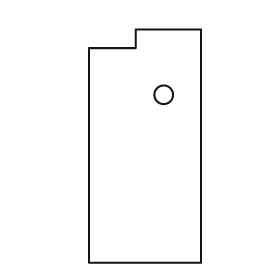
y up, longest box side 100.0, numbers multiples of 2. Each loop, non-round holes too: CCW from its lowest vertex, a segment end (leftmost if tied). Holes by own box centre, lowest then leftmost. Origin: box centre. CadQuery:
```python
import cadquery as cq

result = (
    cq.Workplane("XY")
    .moveTo(-24.0, -50.0)
    .lineTo(24.0, -50.0)
    .lineTo(24.0, 50.0)
    .lineTo(-4.0, 50.0)
    .lineTo(-4.0, 42.0)
    .lineTo(-24.0, 42.0)
    .close()
    .moveTo(8.0, 22.0)
    .circle(4.0)
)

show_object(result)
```